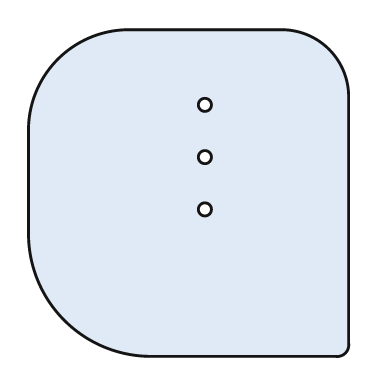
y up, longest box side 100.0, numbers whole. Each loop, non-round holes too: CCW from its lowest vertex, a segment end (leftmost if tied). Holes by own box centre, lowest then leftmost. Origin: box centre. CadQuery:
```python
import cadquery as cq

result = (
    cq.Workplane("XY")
    .moveTo(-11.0, -50.0)
    .lineTo(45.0, -50.0)
    .threePointArc((48.0, -49.0), (49.0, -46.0))
    .lineTo(49.0, 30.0)
    .threePointArc((43.0, 44.0), (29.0, 50.0))
    .lineTo(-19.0, 50.0)
    .threePointArc((-40.0, 41.0), (-49.0, 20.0))
    .lineTo(-49.0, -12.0)
    .threePointArc((-38.0, -39.0), (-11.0, -50.0))
    .close()
    .moveTo(5.0, -5.0)
    .circle(2.0)
    .moveTo(5.0, 11.0)
    .circle(2.0)
    .moveTo(5.0, 27.0)
    .circle(2.0)
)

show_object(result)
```